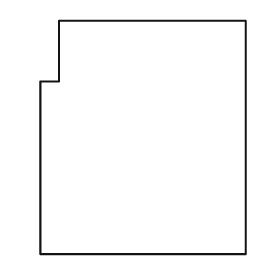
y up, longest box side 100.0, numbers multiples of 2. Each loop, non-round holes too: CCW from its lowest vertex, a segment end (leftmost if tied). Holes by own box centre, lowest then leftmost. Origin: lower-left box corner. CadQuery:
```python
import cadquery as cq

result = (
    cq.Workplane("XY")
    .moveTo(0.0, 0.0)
    .lineTo(88.0, 0.0)
    .lineTo(88.0, 100.0)
    .lineTo(8.0, 100.0)
    .lineTo(8.0, 74.0)
    .lineTo(0.0, 74.0)
    .close()
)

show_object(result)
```